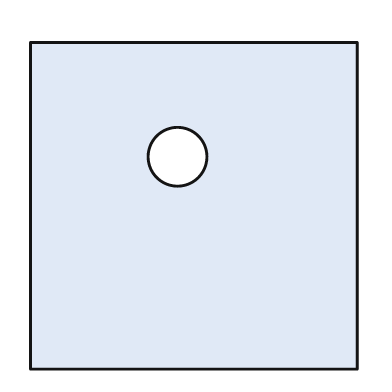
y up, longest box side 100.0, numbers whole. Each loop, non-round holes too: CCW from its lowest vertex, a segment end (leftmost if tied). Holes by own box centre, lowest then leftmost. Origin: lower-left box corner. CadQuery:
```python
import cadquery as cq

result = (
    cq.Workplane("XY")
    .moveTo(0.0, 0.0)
    .lineTo(100.0, 0.0)
    .lineTo(100.0, 100.0)
    .lineTo(0.0, 100.0)
    .close()
    .moveTo(45.0, 65.0)
    .circle(9.0)
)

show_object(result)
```